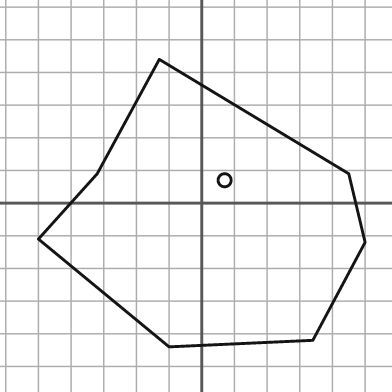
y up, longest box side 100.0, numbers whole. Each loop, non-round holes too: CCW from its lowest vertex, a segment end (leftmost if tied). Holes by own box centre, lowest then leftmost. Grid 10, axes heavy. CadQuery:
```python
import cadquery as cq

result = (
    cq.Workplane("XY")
    .moveTo(-10.0, -44.0)
    .lineTo(34.0, -42.0)
    .lineTo(50.0, -12.0)
    .lineTo(45.0, 9.0)
    .lineTo(-13.0, 44.0)
    .lineTo(-32.0, 9.0)
    .lineTo(-50.0, -11.0)
    .close()
    .moveTo(7.0, 7.0)
    .circle(2.0)
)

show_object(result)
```